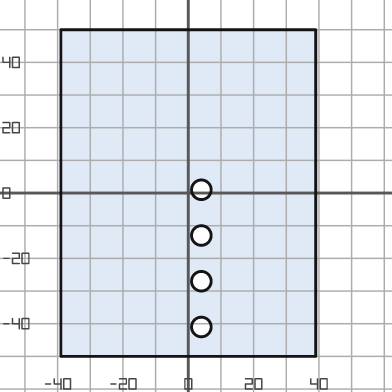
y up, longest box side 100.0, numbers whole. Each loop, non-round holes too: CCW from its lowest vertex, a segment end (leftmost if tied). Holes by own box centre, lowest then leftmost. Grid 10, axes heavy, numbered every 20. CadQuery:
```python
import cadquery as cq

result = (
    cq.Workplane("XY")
    .moveTo(-39.0, -50.0)
    .lineTo(39.0, -50.0)
    .lineTo(39.0, 50.0)
    .lineTo(-39.0, 50.0)
    .close()
    .moveTo(4.0, -41.0)
    .circle(3.0)
    .moveTo(4.0, -27.0)
    .circle(3.0)
    .moveTo(4.0, -13.0)
    .circle(3.0)
    .moveTo(4.0, 1.0)
    .circle(3.0)
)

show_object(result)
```